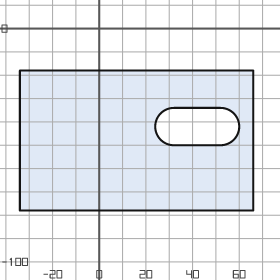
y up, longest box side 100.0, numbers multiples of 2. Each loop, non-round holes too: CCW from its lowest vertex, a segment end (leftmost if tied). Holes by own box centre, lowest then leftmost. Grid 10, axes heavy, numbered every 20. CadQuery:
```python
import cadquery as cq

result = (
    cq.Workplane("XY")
    .moveTo(-34.0, -78.0)
    .lineTo(66.0, -78.0)
    .lineTo(66.0, -18.0)
    .lineTo(-34.0, -18.0)
    .close()
    .moveTo(32.0, -50.0)
    .lineTo(52.0, -50.0)
    .threePointArc((60.0, -42.0), (52.0, -34.0))
    .lineTo(32.0, -34.0)
    .threePointArc((24.0, -42.0), (32.0, -50.0))
    .close()
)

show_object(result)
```